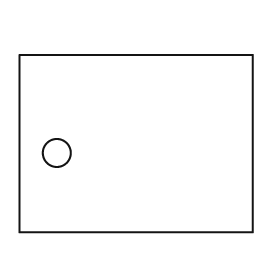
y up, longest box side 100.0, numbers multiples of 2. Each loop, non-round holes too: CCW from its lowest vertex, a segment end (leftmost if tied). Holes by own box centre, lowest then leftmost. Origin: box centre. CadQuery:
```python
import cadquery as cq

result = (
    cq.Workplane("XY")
    .moveTo(-50.0, -38.0)
    .lineTo(50.0, -38.0)
    .lineTo(50.0, 38.0)
    .lineTo(-50.0, 38.0)
    .close()
    .moveTo(-34.0, -4.0)
    .circle(6.0)
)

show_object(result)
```